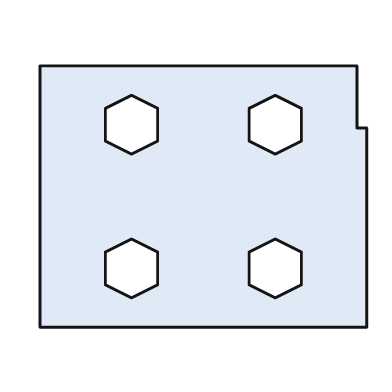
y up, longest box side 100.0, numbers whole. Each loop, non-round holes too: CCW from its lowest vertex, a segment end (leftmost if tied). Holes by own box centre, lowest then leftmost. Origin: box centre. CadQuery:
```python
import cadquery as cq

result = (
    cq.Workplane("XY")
    .moveTo(-50.0, -40.0)
    .lineTo(50.0, -40.0)
    .lineTo(50.0, 21.0)
    .lineTo(47.0, 21.0)
    .lineTo(47.0, 40.0)
    .lineTo(-50.0, 40.0)
    .close()
    .moveTo(-22.0, -31.0)
    .lineTo(-14.0, -27.0)
    .lineTo(-14.0, -17.0)
    .lineTo(-22.0, -13.0)
    .lineTo(-30.0, -17.0)
    .lineTo(-30.0, -27.0)
    .close()
    .moveTo(22.0, -31.0)
    .lineTo(30.0, -27.0)
    .lineTo(30.0, -17.0)
    .lineTo(22.0, -13.0)
    .lineTo(14.0, -17.0)
    .lineTo(14.0, -27.0)
    .close()
    .moveTo(-22.0, 13.0)
    .lineTo(-14.0, 17.0)
    .lineTo(-14.0, 27.0)
    .lineTo(-22.0, 31.0)
    .lineTo(-30.0, 27.0)
    .lineTo(-30.0, 17.0)
    .close()
    .moveTo(22.0, 13.0)
    .lineTo(30.0, 17.0)
    .lineTo(30.0, 27.0)
    .lineTo(22.0, 31.0)
    .lineTo(14.0, 27.0)
    .lineTo(14.0, 17.0)
    .close()
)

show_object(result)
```